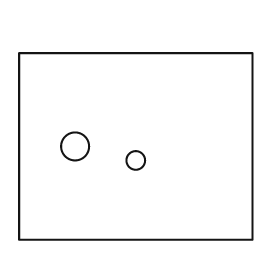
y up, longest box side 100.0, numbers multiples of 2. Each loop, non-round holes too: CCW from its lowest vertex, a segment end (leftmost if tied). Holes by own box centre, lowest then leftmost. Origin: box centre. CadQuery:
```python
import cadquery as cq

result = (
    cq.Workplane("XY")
    .moveTo(-50.0, -40.0)
    .lineTo(50.0, -40.0)
    .lineTo(50.0, 40.0)
    .lineTo(-50.0, 40.0)
    .close()
    .moveTo(0.0, -6.0)
    .circle(4.0)
    .moveTo(-26.0, 0.0)
    .circle(6.0)
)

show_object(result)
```